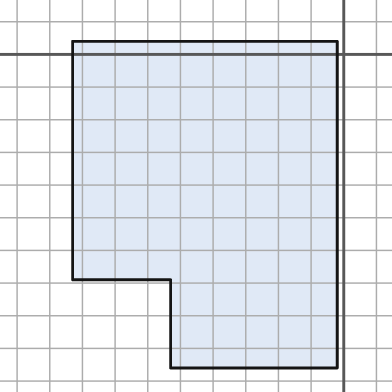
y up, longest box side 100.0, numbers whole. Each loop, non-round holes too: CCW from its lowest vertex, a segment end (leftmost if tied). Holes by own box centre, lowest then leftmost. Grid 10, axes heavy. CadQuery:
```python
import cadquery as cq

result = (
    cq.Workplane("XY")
    .moveTo(-53.0, -96.0)
    .lineTo(-2.0, -96.0)
    .lineTo(-2.0, 4.0)
    .lineTo(-83.0, 4.0)
    .lineTo(-83.0, -69.0)
    .lineTo(-53.0, -69.0)
    .close()
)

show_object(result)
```